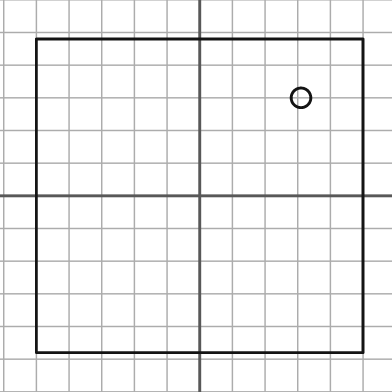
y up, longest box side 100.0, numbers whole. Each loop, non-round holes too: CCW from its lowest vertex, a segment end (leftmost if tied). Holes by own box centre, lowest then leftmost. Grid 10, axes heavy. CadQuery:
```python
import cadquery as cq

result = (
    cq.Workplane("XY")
    .moveTo(-50.0, -48.0)
    .lineTo(50.0, -48.0)
    .lineTo(50.0, 48.0)
    .lineTo(-50.0, 48.0)
    .close()
    .moveTo(31.0, 30.0)
    .circle(3.0)
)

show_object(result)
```